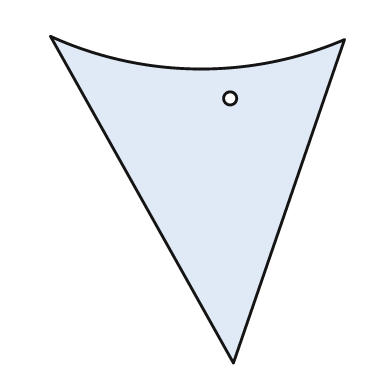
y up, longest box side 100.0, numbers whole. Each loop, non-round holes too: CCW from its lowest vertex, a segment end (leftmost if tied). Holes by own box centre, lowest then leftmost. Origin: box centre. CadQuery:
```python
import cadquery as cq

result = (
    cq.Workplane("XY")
    .moveTo(11.0, -50.0)
    .lineTo(45.0, 49.0)
    .threePointArc((0.0, 40.0), (-45.0, 50.0))
    .close()
    .moveTo(10.0, 31.0)
    .circle(2.0)
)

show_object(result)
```